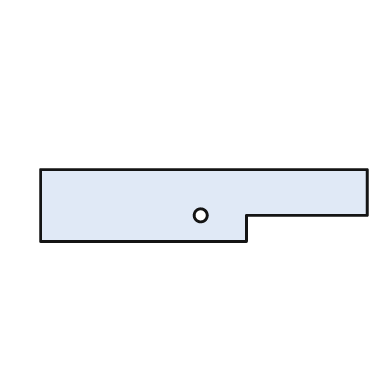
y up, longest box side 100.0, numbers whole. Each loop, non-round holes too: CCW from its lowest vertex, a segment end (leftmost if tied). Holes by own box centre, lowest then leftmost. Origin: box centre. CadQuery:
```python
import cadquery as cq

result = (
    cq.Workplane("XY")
    .moveTo(-50.0, -11.0)
    .lineTo(13.0, -11.0)
    .lineTo(13.0, -3.0)
    .lineTo(50.0, -3.0)
    .lineTo(50.0, 11.0)
    .lineTo(-50.0, 11.0)
    .close()
    .moveTo(-1.0, -3.0)
    .circle(2.0)
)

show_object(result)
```